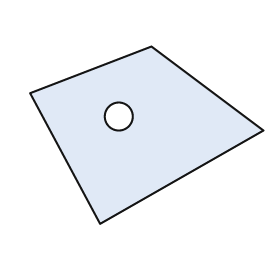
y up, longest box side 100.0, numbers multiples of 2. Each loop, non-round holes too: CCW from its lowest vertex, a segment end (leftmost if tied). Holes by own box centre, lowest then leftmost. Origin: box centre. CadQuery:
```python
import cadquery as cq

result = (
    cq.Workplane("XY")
    .moveTo(-20.0, -38.0)
    .lineTo(50.0, 2.0)
    .lineTo(2.0, 38.0)
    .lineTo(-50.0, 18.0)
    .close()
    .moveTo(-12.0, 8.0)
    .circle(6.0)
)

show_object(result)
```